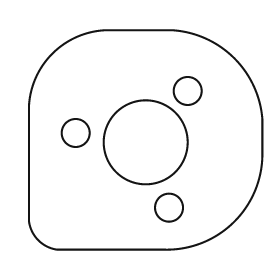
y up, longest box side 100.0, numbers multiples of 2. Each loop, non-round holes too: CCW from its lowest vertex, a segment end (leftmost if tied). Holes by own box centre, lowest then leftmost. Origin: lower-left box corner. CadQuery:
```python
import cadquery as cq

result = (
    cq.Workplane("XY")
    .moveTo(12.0, 0.0)
    .lineTo(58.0, 0.0)
    .threePointArc((88.0, 12.0), (100.0, 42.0))
    .lineTo(100.0, 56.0)
    .threePointArc((88.0, 82.0), (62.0, 94.0))
    .lineTo(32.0, 94.0)
    .threePointArc((10.0, 84.0), (0.0, 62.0))
    .lineTo(0.0, 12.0)
    .threePointArc((4.0, 4.0), (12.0, 0.0))
    .close()
    .moveTo(60.0, 18.0)
    .circle(6.0)
    .moveTo(50.0, 46.0)
    .circle(18.0)
    .moveTo(20.0, 50.0)
    .circle(6.0)
    .moveTo(68.0, 68.0)
    .circle(6.0)
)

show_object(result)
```